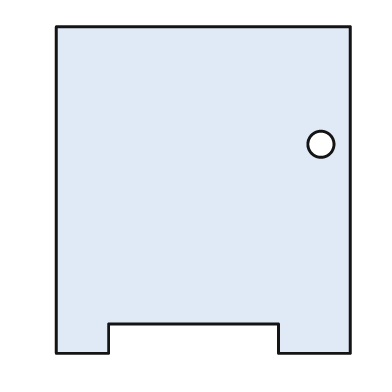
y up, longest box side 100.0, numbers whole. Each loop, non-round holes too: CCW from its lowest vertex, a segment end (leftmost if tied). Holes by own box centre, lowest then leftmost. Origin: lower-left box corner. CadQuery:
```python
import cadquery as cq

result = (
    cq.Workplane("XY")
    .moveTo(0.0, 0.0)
    .lineTo(16.0, 0.0)
    .lineTo(16.0, 9.0)
    .lineTo(68.0, 9.0)
    .lineTo(68.0, 0.0)
    .lineTo(90.0, 0.0)
    .lineTo(90.0, 100.0)
    .lineTo(0.0, 100.0)
    .close()
    .moveTo(81.0, 64.0)
    .circle(4.0)
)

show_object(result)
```